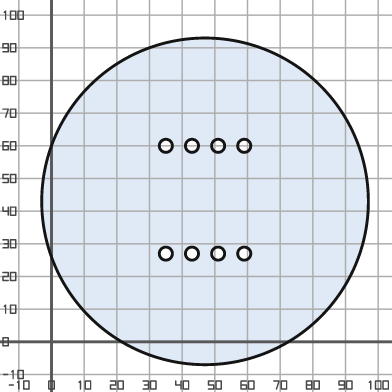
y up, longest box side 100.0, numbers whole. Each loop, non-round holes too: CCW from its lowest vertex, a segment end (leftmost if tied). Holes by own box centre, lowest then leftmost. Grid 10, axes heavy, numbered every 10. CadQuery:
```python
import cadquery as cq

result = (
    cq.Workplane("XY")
    .moveTo(47.0, 43.0)
    .circle(50.0)
    .moveTo(35.0, 27.0)
    .circle(2.0)
    .moveTo(43.0, 27.0)
    .circle(2.0)
    .moveTo(51.0, 27.0)
    .circle(2.0)
    .moveTo(59.0, 27.0)
    .circle(2.0)
    .moveTo(35.0, 60.0)
    .circle(2.0)
    .moveTo(43.0, 60.0)
    .circle(2.0)
    .moveTo(51.0, 60.0)
    .circle(2.0)
    .moveTo(59.0, 60.0)
    .circle(2.0)
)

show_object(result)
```